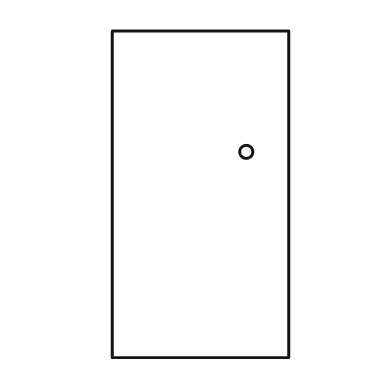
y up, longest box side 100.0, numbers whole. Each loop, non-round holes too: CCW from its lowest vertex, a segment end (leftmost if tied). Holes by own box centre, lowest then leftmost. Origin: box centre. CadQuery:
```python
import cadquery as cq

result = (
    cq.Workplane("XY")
    .moveTo(-27.0, -50.0)
    .lineTo(27.0, -50.0)
    .lineTo(27.0, 50.0)
    .lineTo(-27.0, 50.0)
    .close()
    .moveTo(14.0, 13.0)
    .circle(2.0)
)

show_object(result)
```